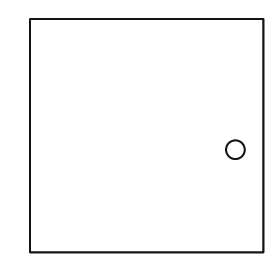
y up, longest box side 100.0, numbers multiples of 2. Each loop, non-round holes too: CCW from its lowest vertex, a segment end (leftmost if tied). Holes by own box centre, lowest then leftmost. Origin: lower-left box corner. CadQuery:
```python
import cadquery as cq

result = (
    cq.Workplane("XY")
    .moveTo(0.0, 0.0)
    .lineTo(100.0, 0.0)
    .lineTo(100.0, 100.0)
    .lineTo(0.0, 100.0)
    .close()
    .moveTo(88.0, 44.0)
    .circle(4.0)
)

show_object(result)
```